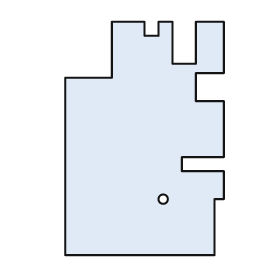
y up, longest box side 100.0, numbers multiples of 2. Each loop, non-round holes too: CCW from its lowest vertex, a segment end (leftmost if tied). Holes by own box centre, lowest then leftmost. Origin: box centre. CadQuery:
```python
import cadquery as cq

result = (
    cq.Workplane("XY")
    .moveTo(-34.0, -50.0)
    .lineTo(30.0, -50.0)
    .lineTo(30.0, -26.0)
    .lineTo(34.0, -26.0)
    .lineTo(34.0, -14.0)
    .lineTo(16.0, -14.0)
    .lineTo(16.0, -8.0)
    .lineTo(34.0, -8.0)
    .lineTo(34.0, 16.0)
    .lineTo(22.0, 16.0)
    .lineTo(22.0, 28.0)
    .lineTo(34.0, 28.0)
    .lineTo(34.0, 50.0)
    .lineTo(22.0, 50.0)
    .lineTo(22.0, 32.0)
    .lineTo(12.0, 32.0)
    .lineTo(12.0, 50.0)
    .lineTo(6.0, 50.0)
    .lineTo(6.0, 44.0)
    .lineTo(0.0, 44.0)
    .lineTo(0.0, 50.0)
    .lineTo(-14.0, 50.0)
    .lineTo(-14.0, 26.0)
    .lineTo(-34.0, 26.0)
    .close()
    .moveTo(8.0, -26.0)
    .circle(2.0)
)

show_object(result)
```